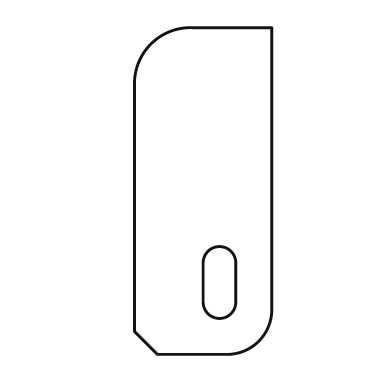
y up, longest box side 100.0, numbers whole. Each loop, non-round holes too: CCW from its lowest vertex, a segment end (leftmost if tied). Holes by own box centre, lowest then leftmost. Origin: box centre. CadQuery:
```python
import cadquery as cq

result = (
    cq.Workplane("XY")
    .moveTo(-14.0, -50.0)
    .lineTo(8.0, -50.0)
    .threePointArc((17.0, -46.0), (21.0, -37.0))
    .lineTo(21.0, 50.0)
    .lineTo(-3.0, 50.0)
    .threePointArc((-16.0, 45.0), (-21.0, 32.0))
    .lineTo(-21.0, -43.0)
    .close()
    .moveTo(0.0, -34.0)
    .threePointArc((5.0, -39.0), (10.0, -34.0))
    .lineTo(10.0, -22.0)
    .threePointArc((5.0, -17.0), (0.0, -22.0))
    .close()
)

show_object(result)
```